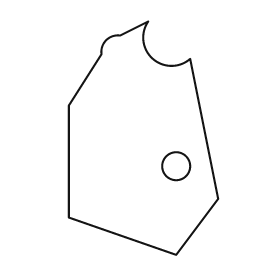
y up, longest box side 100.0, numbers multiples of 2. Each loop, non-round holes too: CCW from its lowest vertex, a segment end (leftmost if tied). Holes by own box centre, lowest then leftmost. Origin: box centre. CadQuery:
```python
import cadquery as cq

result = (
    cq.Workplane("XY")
    .moveTo(14.0, -50.0)
    .lineTo(32.0, -26.0)
    .lineTo(20.0, 34.0)
    .threePointArc((4.0, 34.0), (2.0, 50.0))
    .lineTo(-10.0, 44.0)
    .threePointArc((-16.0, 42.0), (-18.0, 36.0))
    .lineTo(-32.0, 14.0)
    .lineTo(-32.0, -34.0)
    .close()
    .moveTo(14.0, -12.0)
    .circle(6.0)
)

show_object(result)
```